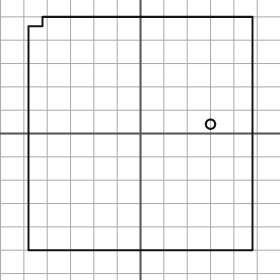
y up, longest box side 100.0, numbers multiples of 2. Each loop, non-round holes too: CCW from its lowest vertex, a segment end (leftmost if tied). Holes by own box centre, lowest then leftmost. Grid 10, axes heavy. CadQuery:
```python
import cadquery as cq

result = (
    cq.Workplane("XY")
    .moveTo(-48.0, -50.0)
    .lineTo(48.0, -50.0)
    .lineTo(48.0, 50.0)
    .lineTo(-42.0, 50.0)
    .lineTo(-42.0, 46.0)
    .lineTo(-48.0, 46.0)
    .close()
    .moveTo(30.0, 4.0)
    .circle(2.0)
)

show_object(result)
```